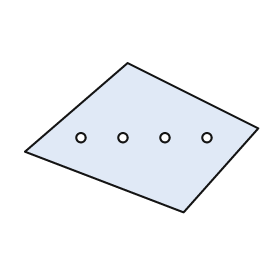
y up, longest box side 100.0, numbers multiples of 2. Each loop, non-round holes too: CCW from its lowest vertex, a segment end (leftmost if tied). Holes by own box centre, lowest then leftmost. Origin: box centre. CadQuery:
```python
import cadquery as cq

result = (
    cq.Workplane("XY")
    .moveTo(18.0, -32.0)
    .lineTo(50.0, 4.0)
    .lineTo(-6.0, 32.0)
    .lineTo(-50.0, -6.0)
    .close()
    .moveTo(-26.0, 0.0)
    .circle(2.0)
    .moveTo(-8.0, 0.0)
    .circle(2.0)
    .moveTo(10.0, 0.0)
    .circle(2.0)
    .moveTo(28.0, 0.0)
    .circle(2.0)
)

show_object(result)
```